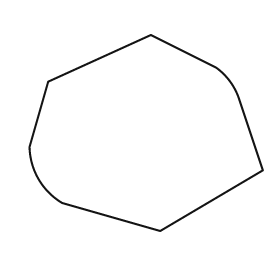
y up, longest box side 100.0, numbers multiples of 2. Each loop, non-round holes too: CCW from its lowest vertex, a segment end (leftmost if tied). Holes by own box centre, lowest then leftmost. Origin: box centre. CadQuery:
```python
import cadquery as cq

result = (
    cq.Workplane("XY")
    .moveTo(6.0, -42.0)
    .lineTo(50.0, -16.0)
    .lineTo(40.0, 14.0)
    .threePointArc((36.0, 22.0), (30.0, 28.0))
    .lineTo(2.0, 42.0)
    .lineTo(-42.0, 22.0)
    .lineTo(-50.0, -6.0)
    .threePointArc((-46.0, -20.0), (-36.0, -30.0))
    .close()
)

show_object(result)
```